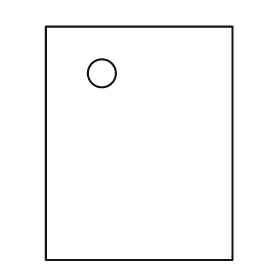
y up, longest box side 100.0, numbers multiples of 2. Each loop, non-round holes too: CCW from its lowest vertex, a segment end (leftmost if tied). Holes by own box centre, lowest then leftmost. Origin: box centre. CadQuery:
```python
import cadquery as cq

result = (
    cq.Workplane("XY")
    .moveTo(-40.0, -50.0)
    .lineTo(40.0, -50.0)
    .lineTo(40.0, 50.0)
    .lineTo(-40.0, 50.0)
    .close()
    .moveTo(-16.0, 30.0)
    .circle(6.0)
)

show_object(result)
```